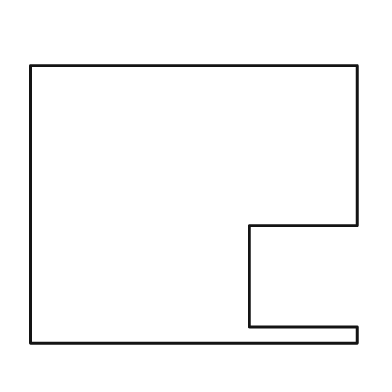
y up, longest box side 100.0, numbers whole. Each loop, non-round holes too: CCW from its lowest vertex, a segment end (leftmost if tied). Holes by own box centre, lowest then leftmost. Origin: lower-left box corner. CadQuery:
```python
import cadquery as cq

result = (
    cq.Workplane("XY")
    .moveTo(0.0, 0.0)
    .lineTo(100.0, 0.0)
    .lineTo(100.0, 5.0)
    .lineTo(67.0, 5.0)
    .lineTo(67.0, 36.0)
    .lineTo(100.0, 36.0)
    .lineTo(100.0, 85.0)
    .lineTo(0.0, 85.0)
    .close()
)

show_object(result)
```